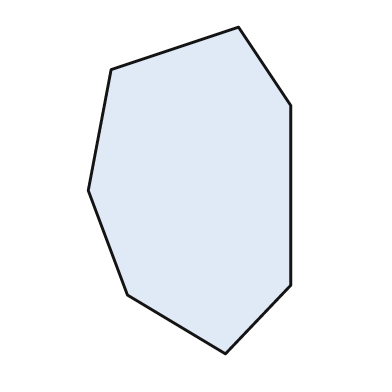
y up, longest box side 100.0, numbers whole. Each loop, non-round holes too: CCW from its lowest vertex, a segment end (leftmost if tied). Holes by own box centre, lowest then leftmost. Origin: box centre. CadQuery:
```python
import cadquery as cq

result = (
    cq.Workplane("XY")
    .moveTo(11.0, -50.0)
    .lineTo(31.0, -29.0)
    .lineTo(31.0, 26.0)
    .lineTo(15.0, 50.0)
    .lineTo(-24.0, 37.0)
    .lineTo(-31.0, 0.0)
    .lineTo(-19.0, -32.0)
    .close()
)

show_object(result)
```